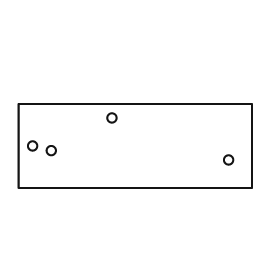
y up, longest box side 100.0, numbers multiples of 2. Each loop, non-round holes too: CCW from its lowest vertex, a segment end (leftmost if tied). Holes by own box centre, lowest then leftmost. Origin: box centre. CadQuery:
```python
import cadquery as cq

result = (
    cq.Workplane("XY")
    .moveTo(-50.0, -18.0)
    .lineTo(50.0, -18.0)
    .lineTo(50.0, 18.0)
    .lineTo(-50.0, 18.0)
    .close()
    .moveTo(40.0, -6.0)
    .circle(2.0)
    .moveTo(-36.0, -2.0)
    .circle(2.0)
    .moveTo(-44.0, 0.0)
    .circle(2.0)
    .moveTo(-10.0, 12.0)
    .circle(2.0)
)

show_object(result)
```